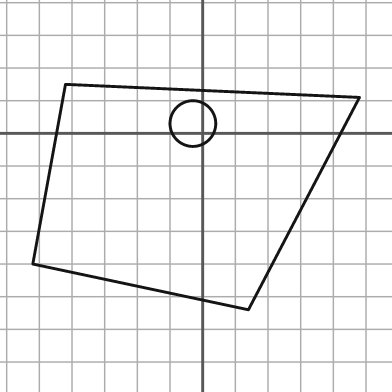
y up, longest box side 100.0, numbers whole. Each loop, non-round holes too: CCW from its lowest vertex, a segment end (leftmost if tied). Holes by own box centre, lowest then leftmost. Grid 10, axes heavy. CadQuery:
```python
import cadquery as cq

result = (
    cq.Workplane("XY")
    .moveTo(14.0, -54.0)
    .lineTo(48.0, 11.0)
    .lineTo(-42.0, 15.0)
    .lineTo(-52.0, -40.0)
    .close()
    .moveTo(-3.0, 3.0)
    .circle(7.0)
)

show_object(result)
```